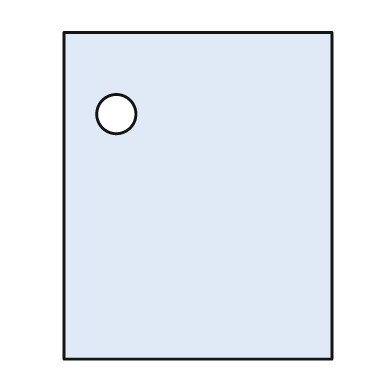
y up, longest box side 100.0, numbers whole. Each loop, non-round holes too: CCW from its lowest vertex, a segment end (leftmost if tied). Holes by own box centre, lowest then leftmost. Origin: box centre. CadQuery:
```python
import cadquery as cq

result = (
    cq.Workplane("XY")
    .moveTo(-41.0, -50.0)
    .lineTo(41.0, -50.0)
    .lineTo(41.0, 50.0)
    .lineTo(-41.0, 50.0)
    .close()
    .moveTo(-25.0, 25.0)
    .circle(6.0)
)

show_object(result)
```